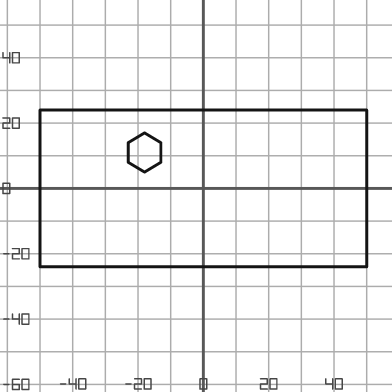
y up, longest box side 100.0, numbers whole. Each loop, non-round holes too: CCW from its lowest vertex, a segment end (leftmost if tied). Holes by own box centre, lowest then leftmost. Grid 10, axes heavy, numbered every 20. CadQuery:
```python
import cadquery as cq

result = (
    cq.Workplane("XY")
    .moveTo(-50.0, -24.0)
    .lineTo(50.0, -24.0)
    .lineTo(50.0, 24.0)
    .lineTo(-50.0, 24.0)
    .close()
    .moveTo(-18.0, 5.0)
    .lineTo(-13.0, 8.0)
    .lineTo(-13.0, 14.0)
    .lineTo(-18.0, 17.0)
    .lineTo(-23.0, 14.0)
    .lineTo(-23.0, 8.0)
    .close()
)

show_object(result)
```